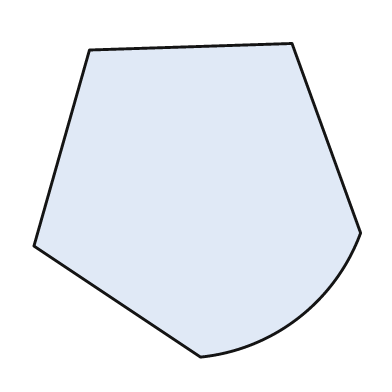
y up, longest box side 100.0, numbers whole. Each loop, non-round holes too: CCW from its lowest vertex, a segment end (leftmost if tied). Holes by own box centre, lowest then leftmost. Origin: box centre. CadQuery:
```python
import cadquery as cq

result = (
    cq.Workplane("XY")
    .moveTo(1.0, -48.0)
    .threePointArc((31.0, -36.0), (50.0, -10.0))
    .lineTo(29.0, 48.0)
    .lineTo(-33.0, 46.0)
    .lineTo(-50.0, -14.0)
    .close()
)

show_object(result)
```